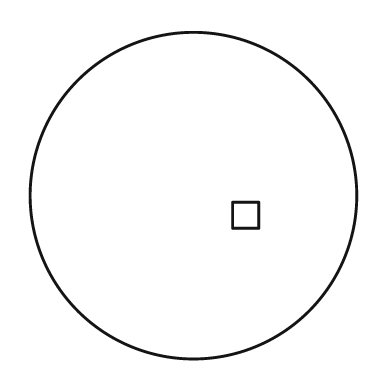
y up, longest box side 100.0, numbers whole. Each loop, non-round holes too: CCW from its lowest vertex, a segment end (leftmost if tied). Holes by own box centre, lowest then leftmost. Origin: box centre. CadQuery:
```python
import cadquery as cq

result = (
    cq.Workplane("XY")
    .moveTo(0.0, 0.0)
    .circle(50.0)
    .moveTo(12.0, -10.0)
    .lineTo(20.0, -10.0)
    .lineTo(20.0, -2.0)
    .lineTo(12.0, -2.0)
    .close()
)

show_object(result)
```